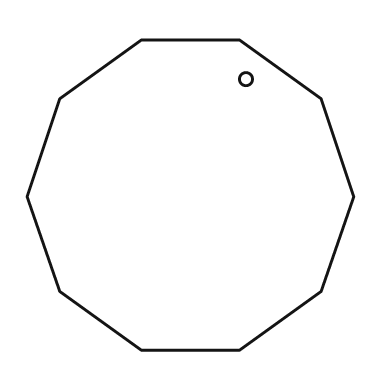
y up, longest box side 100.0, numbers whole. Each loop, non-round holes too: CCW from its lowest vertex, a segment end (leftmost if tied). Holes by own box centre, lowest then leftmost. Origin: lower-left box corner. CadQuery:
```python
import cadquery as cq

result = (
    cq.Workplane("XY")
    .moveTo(35.0, 0.0)
    .lineTo(65.0, 0.0)
    .lineTo(90.0, 18.0)
    .lineTo(100.0, 47.0)
    .lineTo(90.0, 77.0)
    .lineTo(65.0, 95.0)
    .lineTo(35.0, 95.0)
    .lineTo(10.0, 77.0)
    .lineTo(0.0, 47.0)
    .lineTo(10.0, 18.0)
    .close()
    .moveTo(67.0, 83.0)
    .circle(2.0)
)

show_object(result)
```